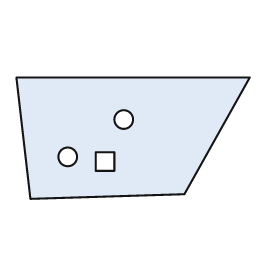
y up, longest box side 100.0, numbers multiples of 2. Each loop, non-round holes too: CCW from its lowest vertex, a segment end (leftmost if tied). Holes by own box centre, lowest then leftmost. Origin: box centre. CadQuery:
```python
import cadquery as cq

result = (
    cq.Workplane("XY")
    .moveTo(-44.0, -26.0)
    .lineTo(22.0, -24.0)
    .lineTo(50.0, 26.0)
    .lineTo(-50.0, 26.0)
    .close()
    .moveTo(-16.0, -14.0)
    .lineTo(-8.0, -14.0)
    .lineTo(-8.0, -6.0)
    .lineTo(-16.0, -6.0)
    .close()
    .moveTo(-28.0, -8.0)
    .circle(4.0)
    .moveTo(-4.0, 8.0)
    .circle(4.0)
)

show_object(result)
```